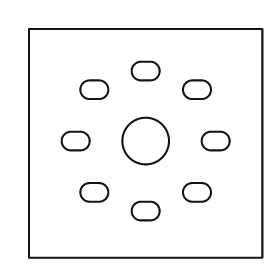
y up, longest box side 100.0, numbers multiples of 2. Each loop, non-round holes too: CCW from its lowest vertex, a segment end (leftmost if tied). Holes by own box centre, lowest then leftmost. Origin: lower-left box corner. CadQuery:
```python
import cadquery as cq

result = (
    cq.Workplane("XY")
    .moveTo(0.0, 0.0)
    .lineTo(100.0, 0.0)
    .lineTo(100.0, 98.0)
    .lineTo(0.0, 98.0)
    .close()
    .moveTo(48.0, 16.0)
    .lineTo(52.0, 16.0)
    .threePointArc((56.0, 20.0), (52.0, 24.0))
    .lineTo(48.0, 24.0)
    .threePointArc((44.0, 20.0), (48.0, 16.0))
    .close()
    .moveTo(26.0, 24.0)
    .lineTo(30.0, 24.0)
    .threePointArc((34.0, 28.0), (30.0, 32.0))
    .lineTo(26.0, 32.0)
    .threePointArc((22.0, 28.0), (26.0, 24.0))
    .close()
    .moveTo(70.0, 24.0)
    .lineTo(74.0, 24.0)
    .threePointArc((78.0, 28.0), (74.0, 32.0))
    .lineTo(70.0, 32.0)
    .threePointArc((66.0, 28.0), (70.0, 24.0))
    .close()
    .moveTo(18.0, 46.0)
    .lineTo(22.0, 46.0)
    .threePointArc((26.0, 50.0), (22.0, 54.0))
    .lineTo(18.0, 54.0)
    .threePointArc((14.0, 50.0), (18.0, 46.0))
    .close()
    .moveTo(50.0, 50.0)
    .circle(10.0)
    .moveTo(78.0, 46.0)
    .lineTo(82.0, 46.0)
    .threePointArc((86.0, 50.0), (82.0, 54.0))
    .lineTo(78.0, 54.0)
    .threePointArc((74.0, 50.0), (78.0, 46.0))
    .close()
    .moveTo(26.0, 68.0)
    .lineTo(30.0, 68.0)
    .threePointArc((34.0, 72.0), (30.0, 76.0))
    .lineTo(26.0, 76.0)
    .threePointArc((22.0, 72.0), (26.0, 68.0))
    .close()
    .moveTo(70.0, 68.0)
    .lineTo(74.0, 68.0)
    .threePointArc((78.0, 72.0), (74.0, 76.0))
    .lineTo(70.0, 76.0)
    .threePointArc((66.0, 72.0), (70.0, 68.0))
    .close()
    .moveTo(48.0, 76.0)
    .lineTo(52.0, 76.0)
    .threePointArc((56.0, 80.0), (52.0, 84.0))
    .lineTo(48.0, 84.0)
    .threePointArc((44.0, 80.0), (48.0, 76.0))
    .close()
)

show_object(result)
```